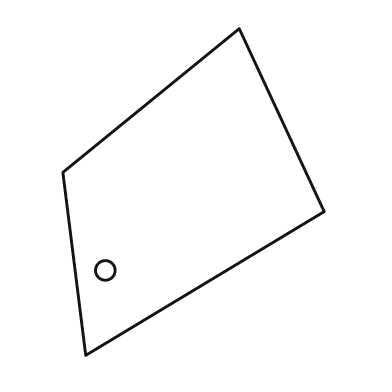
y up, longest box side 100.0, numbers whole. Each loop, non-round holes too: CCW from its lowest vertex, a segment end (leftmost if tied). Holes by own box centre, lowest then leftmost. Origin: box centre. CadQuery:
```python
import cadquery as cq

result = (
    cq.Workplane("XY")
    .moveTo(-33.0, -50.0)
    .lineTo(40.0, -6.0)
    .lineTo(14.0, 50.0)
    .lineTo(-40.0, 6.0)
    .close()
    .moveTo(-27.0, -24.0)
    .circle(3.0)
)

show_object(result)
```